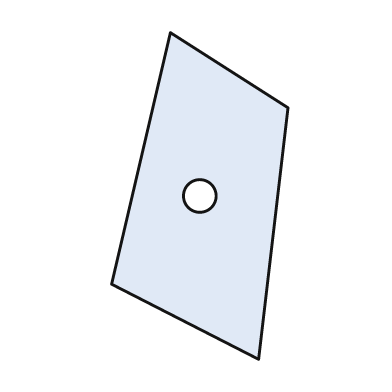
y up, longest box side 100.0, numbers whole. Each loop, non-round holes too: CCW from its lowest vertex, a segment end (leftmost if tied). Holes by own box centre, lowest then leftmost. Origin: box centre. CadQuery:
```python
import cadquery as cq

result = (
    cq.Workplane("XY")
    .moveTo(18.0, -50.0)
    .lineTo(27.0, 27.0)
    .lineTo(-9.0, 50.0)
    .lineTo(-27.0, -27.0)
    .close()
    .moveTo(0.0, 0.0)
    .circle(5.0)
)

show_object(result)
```